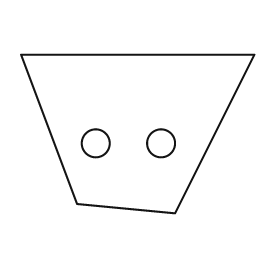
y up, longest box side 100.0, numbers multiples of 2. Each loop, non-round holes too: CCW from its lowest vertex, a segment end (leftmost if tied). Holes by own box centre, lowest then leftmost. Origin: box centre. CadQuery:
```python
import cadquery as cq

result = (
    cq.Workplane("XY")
    .moveTo(16.0, -34.0)
    .lineTo(50.0, 34.0)
    .lineTo(-50.0, 34.0)
    .lineTo(-26.0, -30.0)
    .close()
    .moveTo(-18.0, -4.0)
    .circle(6.0)
    .moveTo(10.0, -4.0)
    .circle(6.0)
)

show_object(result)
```